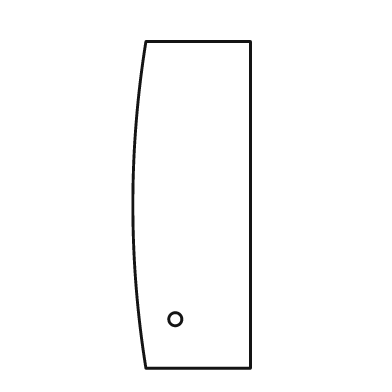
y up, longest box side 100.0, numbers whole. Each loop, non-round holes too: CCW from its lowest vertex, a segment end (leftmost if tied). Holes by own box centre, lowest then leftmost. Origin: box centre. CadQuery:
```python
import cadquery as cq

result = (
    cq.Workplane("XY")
    .moveTo(-14.0, -50.0)
    .lineTo(18.0, -50.0)
    .lineTo(18.0, 50.0)
    .lineTo(-14.0, 50.0)
    .threePointArc((-18.0, 0.0), (-14.0, -50.0))
    .close()
    .moveTo(-5.0, -35.0)
    .circle(2.0)
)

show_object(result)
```